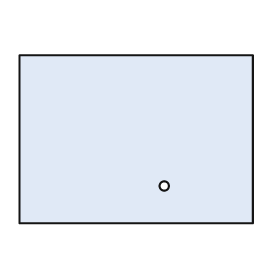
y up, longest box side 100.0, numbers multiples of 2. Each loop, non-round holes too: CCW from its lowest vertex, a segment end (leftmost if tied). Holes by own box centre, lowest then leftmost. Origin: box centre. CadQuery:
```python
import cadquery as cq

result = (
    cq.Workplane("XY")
    .moveTo(-50.0, -36.0)
    .lineTo(50.0, -36.0)
    .lineTo(50.0, 36.0)
    .lineTo(-50.0, 36.0)
    .close()
    .moveTo(12.0, -20.0)
    .circle(2.0)
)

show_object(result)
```